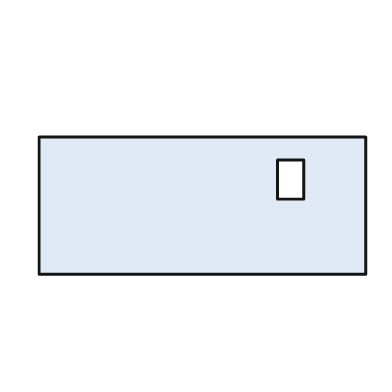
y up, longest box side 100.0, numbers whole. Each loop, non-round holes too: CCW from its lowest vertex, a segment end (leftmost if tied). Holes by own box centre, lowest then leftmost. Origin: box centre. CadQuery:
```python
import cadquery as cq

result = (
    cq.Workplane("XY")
    .moveTo(-50.0, -21.0)
    .lineTo(50.0, -21.0)
    .lineTo(50.0, 21.0)
    .lineTo(-50.0, 21.0)
    .close()
    .moveTo(23.0, 2.0)
    .lineTo(31.0, 2.0)
    .lineTo(31.0, 14.0)
    .lineTo(23.0, 14.0)
    .close()
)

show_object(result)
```